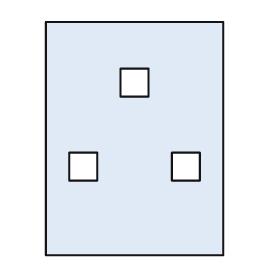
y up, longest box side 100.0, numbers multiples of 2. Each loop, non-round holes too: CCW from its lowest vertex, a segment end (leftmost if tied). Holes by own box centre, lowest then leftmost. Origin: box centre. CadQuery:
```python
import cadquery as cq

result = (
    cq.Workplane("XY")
    .moveTo(-38.0, -50.0)
    .lineTo(38.0, -50.0)
    .lineTo(38.0, 50.0)
    .lineTo(-38.0, 50.0)
    .close()
    .moveTo(-28.0, -18.0)
    .lineTo(-16.0, -18.0)
    .lineTo(-16.0, -6.0)
    .lineTo(-28.0, -6.0)
    .close()
    .moveTo(16.0, -18.0)
    .lineTo(28.0, -18.0)
    .lineTo(28.0, -6.0)
    .lineTo(16.0, -6.0)
    .close()
    .moveTo(-6.0, 18.0)
    .lineTo(6.0, 18.0)
    .lineTo(6.0, 30.0)
    .lineTo(-6.0, 30.0)
    .close()
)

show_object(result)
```